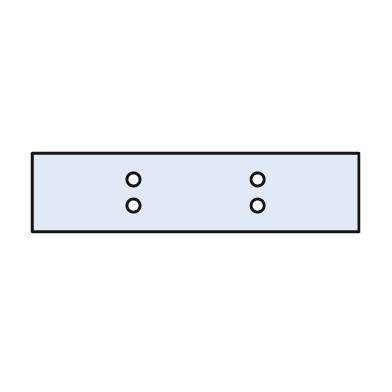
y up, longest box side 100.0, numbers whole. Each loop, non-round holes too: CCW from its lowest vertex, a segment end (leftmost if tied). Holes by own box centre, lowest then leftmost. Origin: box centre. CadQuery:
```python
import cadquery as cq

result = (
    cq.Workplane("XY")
    .moveTo(-50.0, -12.0)
    .lineTo(50.0, -12.0)
    .lineTo(50.0, 12.0)
    .lineTo(-50.0, 12.0)
    .close()
    .moveTo(-19.0, -4.0)
    .circle(2.0)
    .moveTo(19.0, -4.0)
    .circle(2.0)
    .moveTo(-19.0, 4.0)
    .circle(2.0)
    .moveTo(19.0, 4.0)
    .circle(2.0)
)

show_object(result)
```